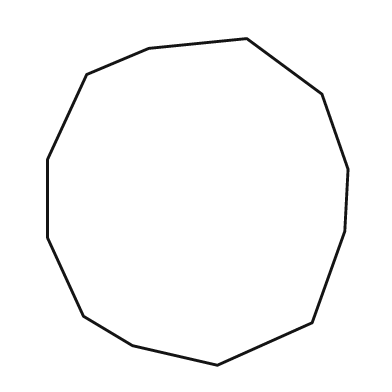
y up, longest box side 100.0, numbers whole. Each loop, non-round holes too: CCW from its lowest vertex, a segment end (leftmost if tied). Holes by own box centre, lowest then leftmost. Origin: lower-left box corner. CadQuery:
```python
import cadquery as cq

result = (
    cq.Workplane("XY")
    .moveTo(52.0, 0.0)
    .lineTo(81.0, 13.0)
    .lineTo(91.0, 41.0)
    .lineTo(92.0, 60.0)
    .lineTo(84.0, 83.0)
    .lineTo(61.0, 100.0)
    .lineTo(31.0, 97.0)
    .lineTo(12.0, 89.0)
    .lineTo(0.0, 63.0)
    .lineTo(0.0, 39.0)
    .lineTo(11.0, 15.0)
    .lineTo(26.0, 6.0)
    .close()
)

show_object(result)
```